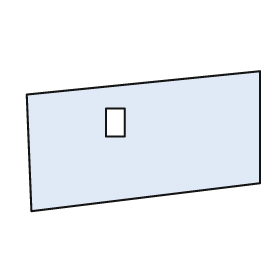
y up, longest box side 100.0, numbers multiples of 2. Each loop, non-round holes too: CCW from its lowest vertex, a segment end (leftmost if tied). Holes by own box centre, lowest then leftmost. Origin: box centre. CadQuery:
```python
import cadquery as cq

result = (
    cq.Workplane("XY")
    .moveTo(-48.0, -30.0)
    .lineTo(50.0, -18.0)
    .lineTo(50.0, 30.0)
    .lineTo(-50.0, 20.0)
    .close()
    .moveTo(-16.0, 2.0)
    .lineTo(-8.0, 2.0)
    .lineTo(-8.0, 14.0)
    .lineTo(-16.0, 14.0)
    .close()
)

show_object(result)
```